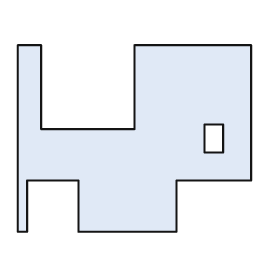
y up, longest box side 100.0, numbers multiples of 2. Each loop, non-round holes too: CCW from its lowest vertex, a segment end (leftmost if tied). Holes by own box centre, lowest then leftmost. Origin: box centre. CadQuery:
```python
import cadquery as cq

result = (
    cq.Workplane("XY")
    .moveTo(-50.0, -40.0)
    .lineTo(-46.0, -40.0)
    .lineTo(-46.0, -18.0)
    .lineTo(-24.0, -18.0)
    .lineTo(-24.0, -40.0)
    .lineTo(18.0, -40.0)
    .lineTo(18.0, -18.0)
    .lineTo(50.0, -18.0)
    .lineTo(50.0, 40.0)
    .lineTo(0.0, 40.0)
    .lineTo(0.0, 4.0)
    .lineTo(-40.0, 4.0)
    .lineTo(-40.0, 40.0)
    .lineTo(-50.0, 40.0)
    .close()
    .moveTo(30.0, -6.0)
    .lineTo(38.0, -6.0)
    .lineTo(38.0, 6.0)
    .lineTo(30.0, 6.0)
    .close()
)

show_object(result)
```